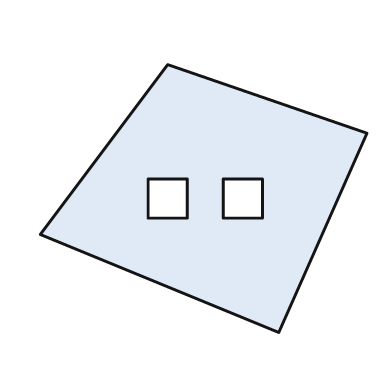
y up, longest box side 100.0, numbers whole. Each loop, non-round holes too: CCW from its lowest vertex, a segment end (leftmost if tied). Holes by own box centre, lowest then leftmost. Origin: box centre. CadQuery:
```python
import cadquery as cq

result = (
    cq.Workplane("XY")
    .moveTo(23.0, -41.0)
    .lineTo(50.0, 20.0)
    .lineTo(-11.0, 41.0)
    .lineTo(-50.0, -11.0)
    .close()
    .moveTo(-17.0, -6.0)
    .lineTo(-5.0, -6.0)
    .lineTo(-5.0, 6.0)
    .lineTo(-17.0, 6.0)
    .close()
    .moveTo(6.0, -6.0)
    .lineTo(18.0, -6.0)
    .lineTo(18.0, 6.0)
    .lineTo(6.0, 6.0)
    .close()
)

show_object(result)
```